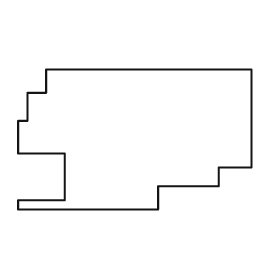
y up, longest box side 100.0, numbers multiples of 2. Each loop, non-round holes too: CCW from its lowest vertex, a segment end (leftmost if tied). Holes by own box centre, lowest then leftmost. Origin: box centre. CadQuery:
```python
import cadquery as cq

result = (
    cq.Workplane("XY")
    .moveTo(-50.0, -30.0)
    .lineTo(10.0, -30.0)
    .lineTo(10.0, -20.0)
    .lineTo(36.0, -20.0)
    .lineTo(36.0, -12.0)
    .lineTo(50.0, -12.0)
    .lineTo(50.0, 30.0)
    .lineTo(-38.0, 30.0)
    .lineTo(-38.0, 20.0)
    .lineTo(-46.0, 20.0)
    .lineTo(-46.0, 8.0)
    .lineTo(-50.0, 8.0)
    .lineTo(-50.0, -6.0)
    .lineTo(-30.0, -6.0)
    .lineTo(-30.0, -26.0)
    .lineTo(-50.0, -26.0)
    .close()
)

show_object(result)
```